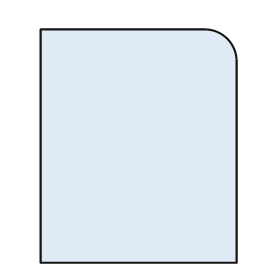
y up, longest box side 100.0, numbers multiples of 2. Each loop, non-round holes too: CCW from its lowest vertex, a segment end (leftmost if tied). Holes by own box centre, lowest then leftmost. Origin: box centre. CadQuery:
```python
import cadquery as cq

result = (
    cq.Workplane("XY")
    .moveTo(-42.0, -50.0)
    .lineTo(42.0, -50.0)
    .lineTo(42.0, 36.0)
    .threePointArc((38.0, 46.0), (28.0, 50.0))
    .lineTo(-42.0, 50.0)
    .close()
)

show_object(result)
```